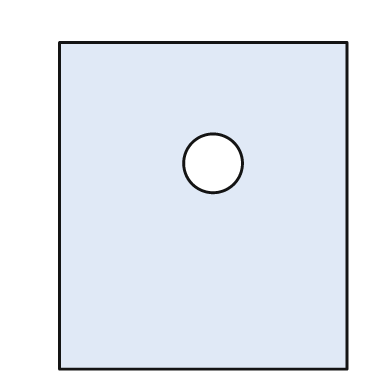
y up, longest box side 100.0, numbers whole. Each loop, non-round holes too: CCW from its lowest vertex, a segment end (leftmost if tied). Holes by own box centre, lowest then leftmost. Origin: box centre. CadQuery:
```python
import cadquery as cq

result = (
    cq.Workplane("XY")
    .moveTo(-44.0, -50.0)
    .lineTo(44.0, -50.0)
    .lineTo(44.0, 50.0)
    .lineTo(-44.0, 50.0)
    .close()
    .moveTo(3.0, 13.0)
    .circle(9.0)
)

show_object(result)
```